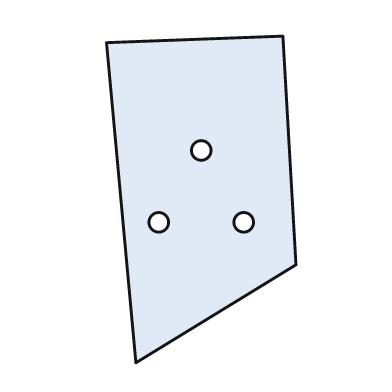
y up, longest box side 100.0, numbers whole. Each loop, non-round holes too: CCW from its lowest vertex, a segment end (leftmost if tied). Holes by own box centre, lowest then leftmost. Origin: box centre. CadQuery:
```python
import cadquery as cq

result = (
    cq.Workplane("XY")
    .moveTo(-20.0, -50.0)
    .lineTo(29.0, -20.0)
    .lineTo(25.0, 50.0)
    .lineTo(-29.0, 48.0)
    .close()
    .moveTo(-13.0, -7.0)
    .circle(3.0)
    .moveTo(13.0, -7.0)
    .circle(3.0)
    .moveTo(0.0, 15.0)
    .circle(3.0)
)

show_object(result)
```